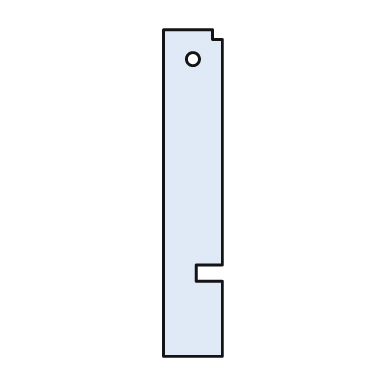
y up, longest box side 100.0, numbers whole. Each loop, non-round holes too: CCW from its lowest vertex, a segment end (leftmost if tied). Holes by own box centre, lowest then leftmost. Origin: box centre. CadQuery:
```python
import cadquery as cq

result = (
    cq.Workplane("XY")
    .moveTo(-9.0, -50.0)
    .lineTo(9.0, -50.0)
    .lineTo(9.0, -27.0)
    .lineTo(1.0, -27.0)
    .lineTo(1.0, -22.0)
    .lineTo(9.0, -22.0)
    .lineTo(9.0, 47.0)
    .lineTo(6.0, 47.0)
    .lineTo(6.0, 50.0)
    .lineTo(-9.0, 50.0)
    .close()
    .moveTo(0.0, 41.0)
    .circle(2.0)
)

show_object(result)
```